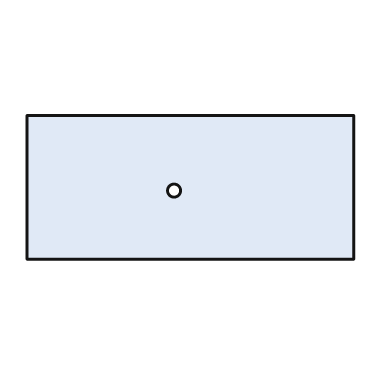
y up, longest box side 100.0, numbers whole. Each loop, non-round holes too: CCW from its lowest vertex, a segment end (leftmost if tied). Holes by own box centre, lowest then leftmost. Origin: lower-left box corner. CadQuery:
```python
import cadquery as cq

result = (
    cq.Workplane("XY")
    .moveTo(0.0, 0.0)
    .lineTo(100.0, 0.0)
    .lineTo(100.0, 44.0)
    .lineTo(0.0, 44.0)
    .close()
    .moveTo(45.0, 21.0)
    .circle(2.0)
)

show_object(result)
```